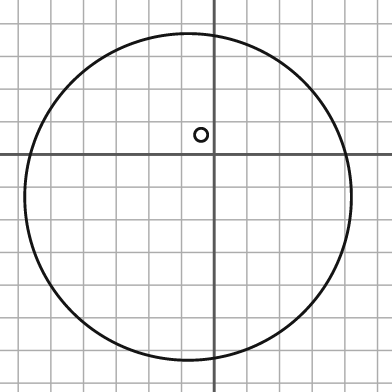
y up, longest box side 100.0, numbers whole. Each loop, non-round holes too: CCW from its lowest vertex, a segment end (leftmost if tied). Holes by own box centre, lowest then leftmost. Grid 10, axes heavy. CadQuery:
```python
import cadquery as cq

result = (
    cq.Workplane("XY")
    .moveTo(-8.0, -13.0)
    .circle(50.0)
    .moveTo(-4.0, 6.0)
    .circle(2.0)
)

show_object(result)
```